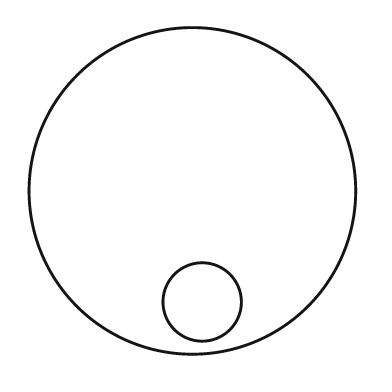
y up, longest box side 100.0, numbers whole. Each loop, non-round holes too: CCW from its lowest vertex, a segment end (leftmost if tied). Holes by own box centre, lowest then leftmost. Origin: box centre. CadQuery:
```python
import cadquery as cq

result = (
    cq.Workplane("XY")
    .moveTo(0.0, 0.0)
    .circle(50.0)
    .moveTo(3.0, -34.0)
    .circle(12.0)
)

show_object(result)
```